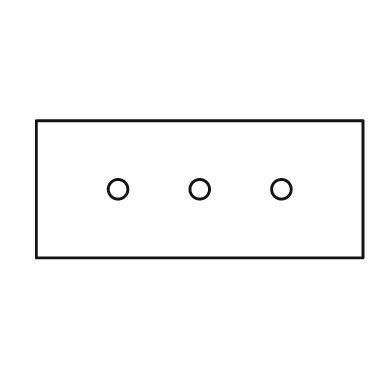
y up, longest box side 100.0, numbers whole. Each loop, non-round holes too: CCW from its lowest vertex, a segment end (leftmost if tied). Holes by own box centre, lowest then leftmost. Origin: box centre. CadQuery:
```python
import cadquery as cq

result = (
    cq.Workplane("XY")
    .moveTo(-50.0, -21.0)
    .lineTo(50.0, -21.0)
    .lineTo(50.0, 21.0)
    .lineTo(-50.0, 21.0)
    .close()
    .moveTo(-25.0, 0.0)
    .circle(3.0)
    .moveTo(0.0, 0.0)
    .circle(3.0)
    .moveTo(25.0, 0.0)
    .circle(3.0)
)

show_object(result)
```